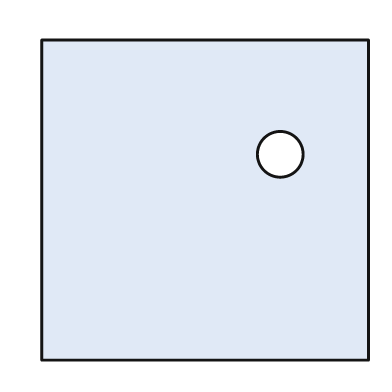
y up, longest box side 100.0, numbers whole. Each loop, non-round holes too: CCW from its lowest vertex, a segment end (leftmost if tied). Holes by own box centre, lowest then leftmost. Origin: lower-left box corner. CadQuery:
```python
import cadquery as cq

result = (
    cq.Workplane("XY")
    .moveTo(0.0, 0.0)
    .lineTo(100.0, 0.0)
    .lineTo(100.0, 98.0)
    .lineTo(0.0, 98.0)
    .close()
    .moveTo(73.0, 63.0)
    .circle(7.0)
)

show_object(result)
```